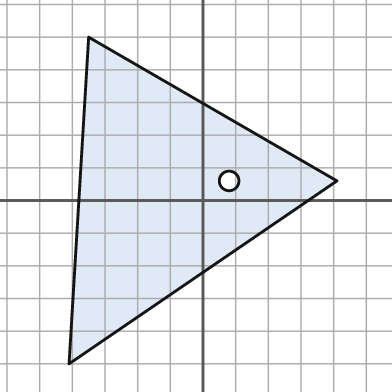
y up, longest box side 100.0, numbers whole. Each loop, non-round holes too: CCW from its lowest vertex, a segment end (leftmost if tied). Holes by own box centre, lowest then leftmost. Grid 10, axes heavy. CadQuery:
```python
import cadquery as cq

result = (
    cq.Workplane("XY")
    .moveTo(-41.0, -50.0)
    .lineTo(41.0, 6.0)
    .lineTo(-35.0, 50.0)
    .close()
    .moveTo(8.0, 6.0)
    .circle(3.0)
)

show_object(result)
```